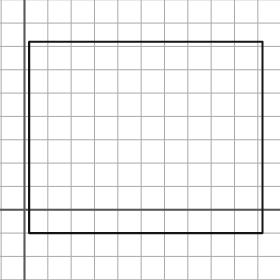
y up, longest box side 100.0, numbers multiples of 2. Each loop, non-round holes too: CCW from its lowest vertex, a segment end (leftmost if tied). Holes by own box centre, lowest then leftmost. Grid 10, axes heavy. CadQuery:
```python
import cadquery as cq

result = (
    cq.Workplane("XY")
    .moveTo(2.0, -10.0)
    .lineTo(102.0, -10.0)
    .lineTo(102.0, 72.0)
    .lineTo(2.0, 72.0)
    .close()
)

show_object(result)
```